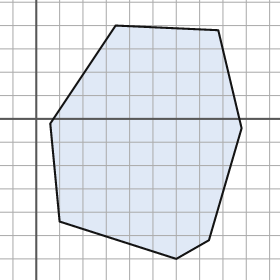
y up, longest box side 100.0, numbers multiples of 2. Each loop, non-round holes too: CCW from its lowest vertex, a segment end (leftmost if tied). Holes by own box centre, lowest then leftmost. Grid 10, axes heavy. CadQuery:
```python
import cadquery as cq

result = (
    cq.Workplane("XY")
    .moveTo(60.0, -60.0)
    .lineTo(74.0, -52.0)
    .lineTo(88.0, -4.0)
    .lineTo(78.0, 38.0)
    .lineTo(34.0, 40.0)
    .lineTo(6.0, -2.0)
    .lineTo(10.0, -44.0)
    .close()
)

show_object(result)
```